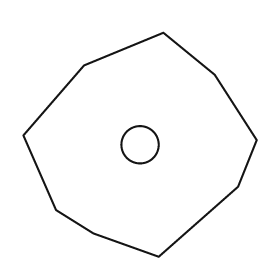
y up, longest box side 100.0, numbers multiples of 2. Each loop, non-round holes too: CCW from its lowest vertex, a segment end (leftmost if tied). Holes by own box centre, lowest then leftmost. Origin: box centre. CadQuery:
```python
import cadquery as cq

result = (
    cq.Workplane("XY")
    .moveTo(8.0, -48.0)
    .lineTo(42.0, -18.0)
    .lineTo(50.0, 2.0)
    .lineTo(32.0, 30.0)
    .lineTo(10.0, 48.0)
    .lineTo(-24.0, 34.0)
    .lineTo(-50.0, 4.0)
    .lineTo(-36.0, -28.0)
    .lineTo(-20.0, -38.0)
    .close()
    .moveTo(0.0, 0.0)
    .circle(8.0)
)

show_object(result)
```